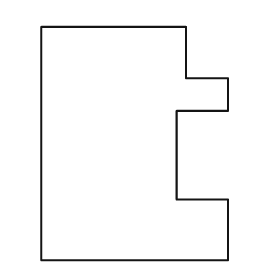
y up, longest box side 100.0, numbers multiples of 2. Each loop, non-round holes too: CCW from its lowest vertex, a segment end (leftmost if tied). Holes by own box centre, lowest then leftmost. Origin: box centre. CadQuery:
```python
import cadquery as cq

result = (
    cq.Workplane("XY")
    .moveTo(-40.0, -50.0)
    .lineTo(40.0, -50.0)
    .lineTo(40.0, -24.0)
    .lineTo(18.0, -24.0)
    .lineTo(18.0, 14.0)
    .lineTo(40.0, 14.0)
    .lineTo(40.0, 28.0)
    .lineTo(22.0, 28.0)
    .lineTo(22.0, 50.0)
    .lineTo(-40.0, 50.0)
    .close()
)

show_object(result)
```